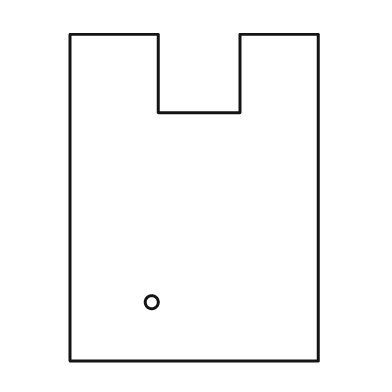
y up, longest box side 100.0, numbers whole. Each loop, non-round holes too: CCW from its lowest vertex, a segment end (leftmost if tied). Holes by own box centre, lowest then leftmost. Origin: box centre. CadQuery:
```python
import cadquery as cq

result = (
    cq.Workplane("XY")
    .moveTo(-38.0, -50.0)
    .lineTo(38.0, -50.0)
    .lineTo(38.0, 50.0)
    .lineTo(14.0, 50.0)
    .lineTo(14.0, 26.0)
    .lineTo(-11.0, 26.0)
    .lineTo(-11.0, 50.0)
    .lineTo(-38.0, 50.0)
    .close()
    .moveTo(-13.0, -32.0)
    .circle(2.0)
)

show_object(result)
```